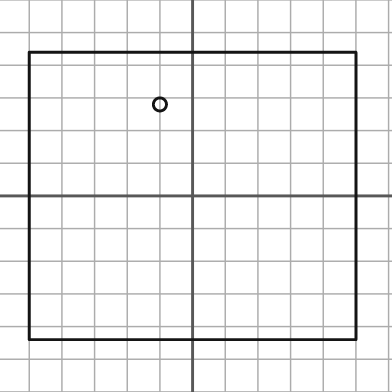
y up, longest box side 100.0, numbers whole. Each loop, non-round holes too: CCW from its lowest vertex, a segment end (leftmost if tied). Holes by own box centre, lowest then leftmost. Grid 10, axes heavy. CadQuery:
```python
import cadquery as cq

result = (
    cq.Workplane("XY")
    .moveTo(-50.0, -44.0)
    .lineTo(50.0, -44.0)
    .lineTo(50.0, 44.0)
    .lineTo(-50.0, 44.0)
    .close()
    .moveTo(-10.0, 28.0)
    .circle(2.0)
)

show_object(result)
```